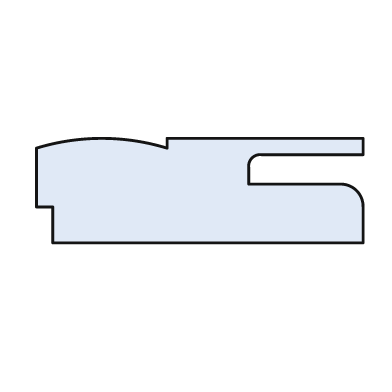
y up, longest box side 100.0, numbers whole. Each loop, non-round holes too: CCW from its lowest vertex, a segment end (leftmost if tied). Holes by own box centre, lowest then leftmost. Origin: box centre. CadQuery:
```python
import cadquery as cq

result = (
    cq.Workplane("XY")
    .moveTo(-45.0, -16.0)
    .lineTo(50.0, -16.0)
    .lineTo(50.0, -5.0)
    .threePointArc((48.0, 0.0), (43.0, 2.0))
    .lineTo(15.0, 2.0)
    .lineTo(15.0, 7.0)
    .threePointArc((16.0, 10.0), (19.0, 11.0))
    .lineTo(50.0, 11.0)
    .lineTo(50.0, 16.0)
    .lineTo(-10.0, 16.0)
    .lineTo(-10.0, 13.0)
    .threePointArc((-30.0, 16.0), (-50.0, 13.0))
    .lineTo(-50.0, -5.0)
    .lineTo(-45.0, -5.0)
    .close()
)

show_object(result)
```